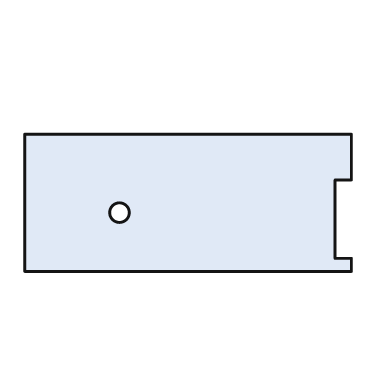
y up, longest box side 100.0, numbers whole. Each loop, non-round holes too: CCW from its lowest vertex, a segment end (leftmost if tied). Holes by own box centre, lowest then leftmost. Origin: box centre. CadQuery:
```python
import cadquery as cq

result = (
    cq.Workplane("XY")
    .moveTo(-50.0, -21.0)
    .lineTo(50.0, -21.0)
    .lineTo(50.0, -17.0)
    .lineTo(45.0, -17.0)
    .lineTo(45.0, 7.0)
    .lineTo(50.0, 7.0)
    .lineTo(50.0, 21.0)
    .lineTo(-50.0, 21.0)
    .close()
    .moveTo(-21.0, -3.0)
    .circle(3.0)
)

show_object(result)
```